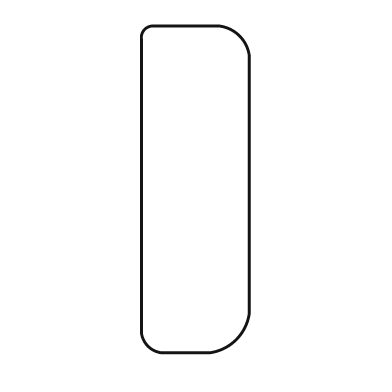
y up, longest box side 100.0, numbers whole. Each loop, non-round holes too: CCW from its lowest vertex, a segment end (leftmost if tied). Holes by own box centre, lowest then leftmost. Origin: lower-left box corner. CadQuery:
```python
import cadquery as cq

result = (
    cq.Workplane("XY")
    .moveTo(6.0, 0.0)
    .lineTo(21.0, 0.0)
    .threePointArc((29.0, 4.0), (33.0, 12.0))
    .lineTo(33.0, 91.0)
    .threePointArc((30.0, 97.0), (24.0, 100.0))
    .lineTo(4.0, 100.0)
    .threePointArc((1.0, 99.0), (0.0, 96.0))
    .lineTo(0.0, 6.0)
    .threePointArc((2.0, 2.0), (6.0, 0.0))
    .close()
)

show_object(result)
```